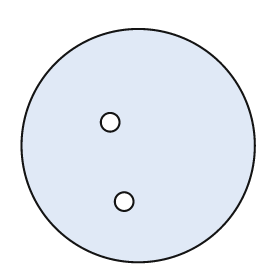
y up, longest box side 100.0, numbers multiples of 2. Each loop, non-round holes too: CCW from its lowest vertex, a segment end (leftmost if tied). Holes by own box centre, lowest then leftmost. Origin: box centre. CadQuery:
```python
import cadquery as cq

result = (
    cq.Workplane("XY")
    .moveTo(0.0, 0.0)
    .circle(50.0)
    .moveTo(-6.0, -24.0)
    .circle(4.0)
    .moveTo(-12.0, 10.0)
    .circle(4.0)
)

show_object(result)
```